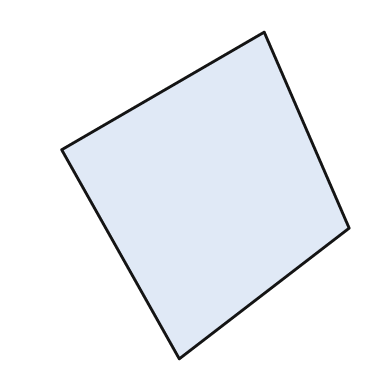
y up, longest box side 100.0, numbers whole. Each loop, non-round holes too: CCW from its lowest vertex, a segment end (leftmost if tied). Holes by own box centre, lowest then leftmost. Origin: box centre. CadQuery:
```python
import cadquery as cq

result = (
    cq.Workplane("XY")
    .moveTo(-8.0, -50.0)
    .lineTo(44.0, -10.0)
    .lineTo(18.0, 50.0)
    .lineTo(-44.0, 14.0)
    .close()
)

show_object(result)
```